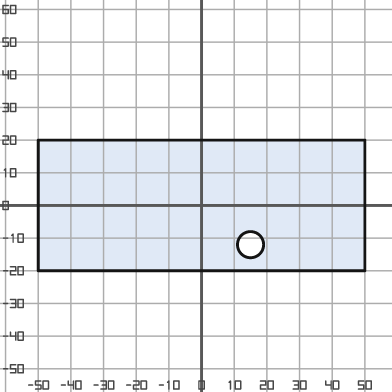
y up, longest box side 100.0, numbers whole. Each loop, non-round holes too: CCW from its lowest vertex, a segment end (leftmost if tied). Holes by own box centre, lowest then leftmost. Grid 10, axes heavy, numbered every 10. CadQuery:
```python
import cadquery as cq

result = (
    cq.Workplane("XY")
    .moveTo(-50.0, -20.0)
    .lineTo(50.0, -20.0)
    .lineTo(50.0, 20.0)
    .lineTo(-50.0, 20.0)
    .close()
    .moveTo(15.0, -12.0)
    .circle(4.0)
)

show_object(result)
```